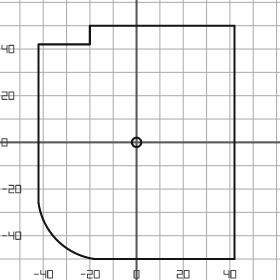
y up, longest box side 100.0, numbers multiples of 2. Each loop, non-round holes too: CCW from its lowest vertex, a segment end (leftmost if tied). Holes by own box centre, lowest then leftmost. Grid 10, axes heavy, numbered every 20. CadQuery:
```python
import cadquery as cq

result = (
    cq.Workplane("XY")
    .moveTo(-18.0, -50.0)
    .lineTo(42.0, -50.0)
    .lineTo(42.0, 50.0)
    .lineTo(-20.0, 50.0)
    .lineTo(-20.0, 42.0)
    .lineTo(-42.0, 42.0)
    .lineTo(-42.0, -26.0)
    .threePointArc((-34.0, -42.0), (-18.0, -50.0))
    .close()
    .moveTo(0.0, 0.0)
    .circle(2.0)
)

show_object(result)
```